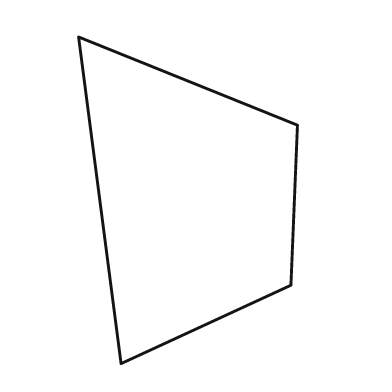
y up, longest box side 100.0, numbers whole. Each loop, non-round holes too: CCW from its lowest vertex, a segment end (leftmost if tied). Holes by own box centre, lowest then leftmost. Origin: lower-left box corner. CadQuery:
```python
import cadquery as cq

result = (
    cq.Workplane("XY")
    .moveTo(13.0, 0.0)
    .lineTo(65.0, 24.0)
    .lineTo(67.0, 73.0)
    .lineTo(0.0, 100.0)
    .close()
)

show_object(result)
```